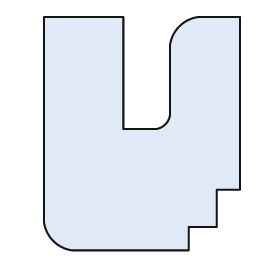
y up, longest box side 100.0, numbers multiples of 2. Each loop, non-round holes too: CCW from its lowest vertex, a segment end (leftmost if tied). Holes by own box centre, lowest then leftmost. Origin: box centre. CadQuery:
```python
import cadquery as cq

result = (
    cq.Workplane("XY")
    .moveTo(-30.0, -50.0)
    .lineTo(20.0, -50.0)
    .lineTo(20.0, -40.0)
    .lineTo(32.0, -40.0)
    .lineTo(32.0, -24.0)
    .lineTo(42.0, -24.0)
    .lineTo(42.0, 50.0)
    .lineTo(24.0, 50.0)
    .threePointArc((16.0, 46.0), (12.0, 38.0))
    .lineTo(12.0, 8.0)
    .threePointArc((10.0, 4.0), (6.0, 2.0))
    .lineTo(-8.0, 2.0)
    .lineTo(-8.0, 50.0)
    .lineTo(-42.0, 50.0)
    .lineTo(-42.0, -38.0)
    .threePointArc((-38.0, -46.0), (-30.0, -50.0))
    .close()
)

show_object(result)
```